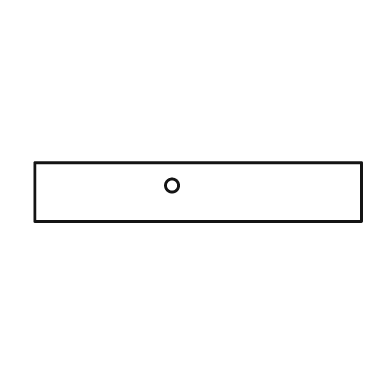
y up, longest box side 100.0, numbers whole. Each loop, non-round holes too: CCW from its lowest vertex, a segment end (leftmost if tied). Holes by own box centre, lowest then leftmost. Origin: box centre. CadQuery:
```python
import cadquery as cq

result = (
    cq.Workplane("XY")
    .moveTo(-50.0, -9.0)
    .lineTo(50.0, -9.0)
    .lineTo(50.0, 9.0)
    .lineTo(-50.0, 9.0)
    .close()
    .moveTo(-8.0, 2.0)
    .circle(2.0)
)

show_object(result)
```